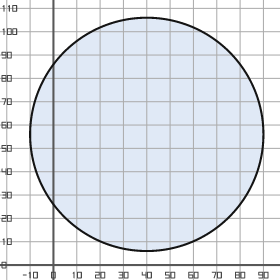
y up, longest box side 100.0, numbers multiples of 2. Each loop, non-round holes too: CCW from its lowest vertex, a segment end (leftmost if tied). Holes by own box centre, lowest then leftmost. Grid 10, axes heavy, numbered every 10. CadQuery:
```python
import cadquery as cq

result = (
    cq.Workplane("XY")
    .moveTo(40.0, 56.0)
    .circle(50.0)
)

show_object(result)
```